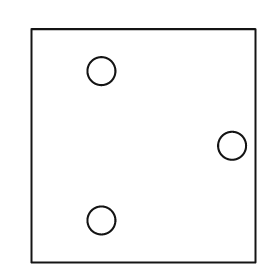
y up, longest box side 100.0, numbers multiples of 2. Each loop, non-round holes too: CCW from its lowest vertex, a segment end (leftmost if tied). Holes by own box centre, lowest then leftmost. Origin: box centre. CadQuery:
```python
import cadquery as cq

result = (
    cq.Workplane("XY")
    .moveTo(-48.0, -50.0)
    .lineTo(48.0, -50.0)
    .lineTo(48.0, 50.0)
    .lineTo(-48.0, 50.0)
    .close()
    .moveTo(-18.0, -32.0)
    .circle(6.0)
    .moveTo(38.0, 0.0)
    .circle(6.0)
    .moveTo(-18.0, 32.0)
    .circle(6.0)
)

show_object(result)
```